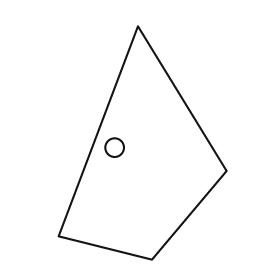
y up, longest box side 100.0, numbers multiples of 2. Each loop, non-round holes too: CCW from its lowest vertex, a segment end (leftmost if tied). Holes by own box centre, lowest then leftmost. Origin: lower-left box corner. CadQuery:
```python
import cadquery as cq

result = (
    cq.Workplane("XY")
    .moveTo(40.0, 0.0)
    .lineTo(72.0, 38.0)
    .lineTo(34.0, 100.0)
    .lineTo(0.0, 10.0)
    .close()
    .moveTo(24.0, 48.0)
    .circle(4.0)
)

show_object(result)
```